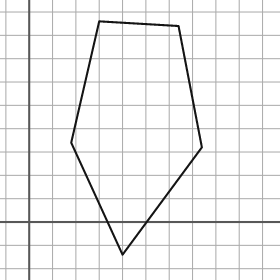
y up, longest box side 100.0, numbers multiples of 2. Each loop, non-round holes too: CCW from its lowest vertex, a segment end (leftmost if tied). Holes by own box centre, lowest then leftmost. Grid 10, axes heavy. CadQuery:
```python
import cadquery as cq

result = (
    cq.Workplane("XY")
    .moveTo(40.0, -14.0)
    .lineTo(74.0, 32.0)
    .lineTo(64.0, 84.0)
    .lineTo(30.0, 86.0)
    .lineTo(18.0, 34.0)
    .close()
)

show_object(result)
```